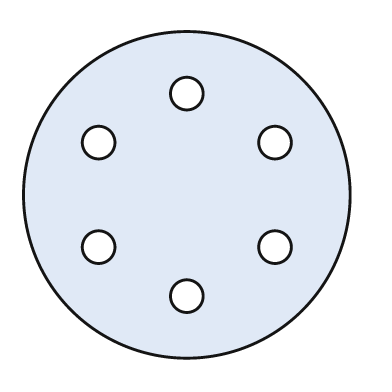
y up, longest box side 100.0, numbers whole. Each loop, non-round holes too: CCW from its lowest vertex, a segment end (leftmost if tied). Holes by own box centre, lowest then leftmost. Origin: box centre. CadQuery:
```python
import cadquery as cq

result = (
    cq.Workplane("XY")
    .moveTo(0.0, 0.0)
    .circle(50.0)
    .moveTo(0.0, -31.0)
    .circle(5.0)
    .moveTo(-27.0, -16.0)
    .circle(5.0)
    .moveTo(27.0, -16.0)
    .circle(5.0)
    .moveTo(-27.0, 16.0)
    .circle(5.0)
    .moveTo(27.0, 16.0)
    .circle(5.0)
    .moveTo(0.0, 31.0)
    .circle(5.0)
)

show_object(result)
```